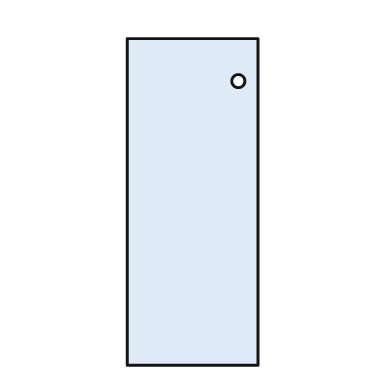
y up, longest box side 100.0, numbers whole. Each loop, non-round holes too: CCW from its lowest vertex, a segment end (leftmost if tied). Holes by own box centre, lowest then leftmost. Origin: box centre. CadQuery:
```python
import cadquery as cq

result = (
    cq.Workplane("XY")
    .moveTo(-20.0, -50.0)
    .lineTo(20.0, -50.0)
    .lineTo(20.0, 50.0)
    .lineTo(-20.0, 50.0)
    .close()
    .moveTo(14.0, 37.0)
    .circle(2.0)
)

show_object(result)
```